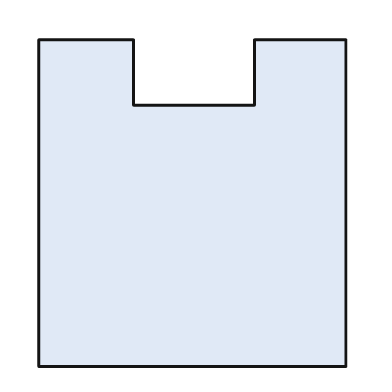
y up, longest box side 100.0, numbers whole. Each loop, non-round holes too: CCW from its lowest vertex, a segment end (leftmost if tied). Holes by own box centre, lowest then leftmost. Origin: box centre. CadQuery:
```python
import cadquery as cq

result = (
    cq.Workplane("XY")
    .moveTo(-47.0, -50.0)
    .lineTo(47.0, -50.0)
    .lineTo(47.0, 50.0)
    .lineTo(19.0, 50.0)
    .lineTo(19.0, 30.0)
    .lineTo(-18.0, 30.0)
    .lineTo(-18.0, 50.0)
    .lineTo(-47.0, 50.0)
    .close()
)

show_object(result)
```